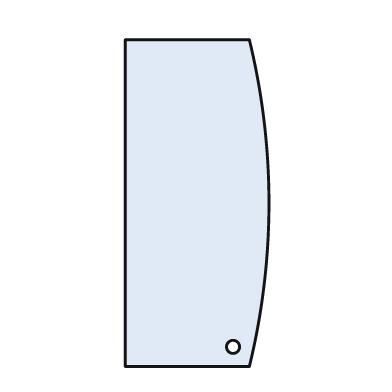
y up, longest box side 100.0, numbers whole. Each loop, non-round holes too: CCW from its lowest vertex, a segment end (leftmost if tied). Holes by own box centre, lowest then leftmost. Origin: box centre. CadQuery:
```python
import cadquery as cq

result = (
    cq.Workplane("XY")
    .moveTo(-22.0, -50.0)
    .lineTo(16.0, -50.0)
    .threePointArc((22.0, 0.0), (16.0, 50.0))
    .lineTo(-22.0, 50.0)
    .close()
    .moveTo(11.0, -44.0)
    .circle(2.0)
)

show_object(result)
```